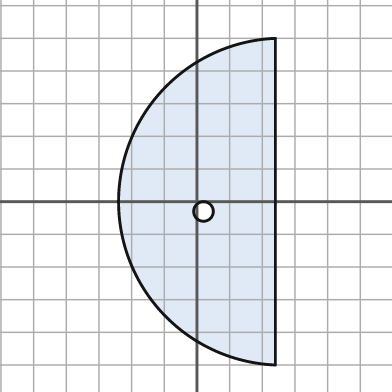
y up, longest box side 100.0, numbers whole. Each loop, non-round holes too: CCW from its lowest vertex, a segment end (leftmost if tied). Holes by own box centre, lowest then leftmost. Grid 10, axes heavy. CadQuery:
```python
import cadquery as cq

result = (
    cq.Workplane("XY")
    .moveTo(24.0, -50.0)
    .lineTo(24.0, 50.0)
    .threePointArc((-24.0, 0.0), (24.0, -50.0))
    .close()
    .moveTo(2.0, -3.0)
    .circle(3.0)
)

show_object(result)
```